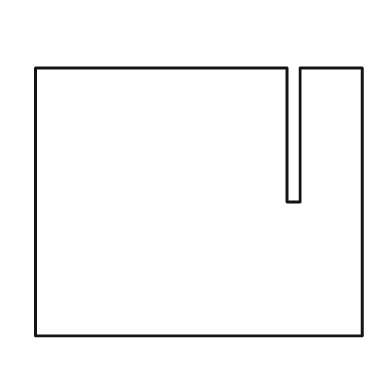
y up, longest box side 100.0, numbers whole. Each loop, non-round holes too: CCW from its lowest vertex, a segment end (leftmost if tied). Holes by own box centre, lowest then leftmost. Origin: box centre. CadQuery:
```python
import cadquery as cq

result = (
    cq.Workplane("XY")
    .moveTo(-50.0, -41.0)
    .lineTo(50.0, -41.0)
    .lineTo(50.0, 41.0)
    .lineTo(31.0, 41.0)
    .lineTo(31.0, 0.0)
    .lineTo(27.0, 0.0)
    .lineTo(27.0, 41.0)
    .lineTo(-50.0, 41.0)
    .close()
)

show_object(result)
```